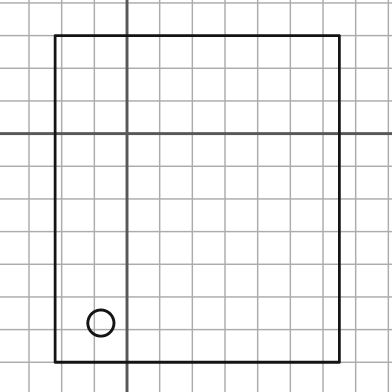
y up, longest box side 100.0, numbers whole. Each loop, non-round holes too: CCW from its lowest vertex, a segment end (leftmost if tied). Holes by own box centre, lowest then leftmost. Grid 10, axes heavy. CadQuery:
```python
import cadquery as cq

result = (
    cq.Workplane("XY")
    .moveTo(-22.0, -70.0)
    .lineTo(65.0, -70.0)
    .lineTo(65.0, 30.0)
    .lineTo(-22.0, 30.0)
    .close()
    .moveTo(-8.0, -58.0)
    .circle(4.0)
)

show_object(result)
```